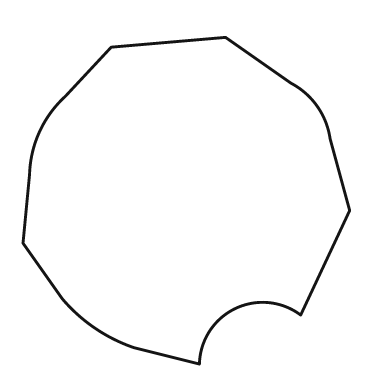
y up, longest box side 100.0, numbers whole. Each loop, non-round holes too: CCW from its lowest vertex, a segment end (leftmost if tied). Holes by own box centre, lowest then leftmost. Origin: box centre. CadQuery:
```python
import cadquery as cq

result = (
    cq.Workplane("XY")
    .moveTo(4.0, -50.0)
    .threePointArc((15.0, -33.0), (35.0, -35.0))
    .lineTo(50.0, -3.0)
    .lineTo(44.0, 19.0)
    .threePointArc((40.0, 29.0), (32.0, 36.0))
    .lineTo(12.0, 50.0)
    .lineTo(-23.0, 47.0)
    .lineTo(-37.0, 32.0)
    .threePointArc((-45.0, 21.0), (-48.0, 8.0))
    .lineTo(-50.0, -13.0)
    .lineTo(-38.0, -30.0)
    .threePointArc((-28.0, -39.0), (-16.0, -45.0))
    .close()
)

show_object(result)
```